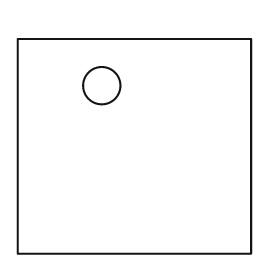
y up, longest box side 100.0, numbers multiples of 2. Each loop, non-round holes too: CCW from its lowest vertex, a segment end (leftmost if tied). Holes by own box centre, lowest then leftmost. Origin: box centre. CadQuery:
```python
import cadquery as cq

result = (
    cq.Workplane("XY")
    .moveTo(-50.0, -46.0)
    .lineTo(50.0, -46.0)
    .lineTo(50.0, 46.0)
    .lineTo(-50.0, 46.0)
    .close()
    .moveTo(-14.0, 26.0)
    .circle(8.0)
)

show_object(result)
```